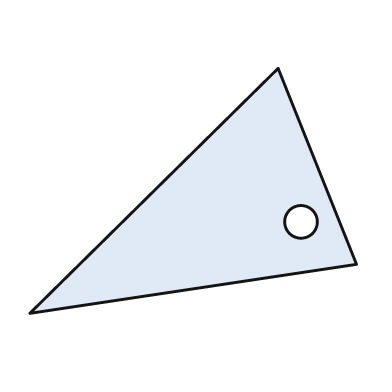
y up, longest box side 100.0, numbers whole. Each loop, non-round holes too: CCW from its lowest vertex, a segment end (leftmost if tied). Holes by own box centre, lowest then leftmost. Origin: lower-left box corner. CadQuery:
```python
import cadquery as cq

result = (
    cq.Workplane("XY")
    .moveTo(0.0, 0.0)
    .lineTo(100.0, 15.0)
    .lineTo(76.0, 75.0)
    .close()
    .moveTo(83.0, 28.0)
    .circle(5.0)
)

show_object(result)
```